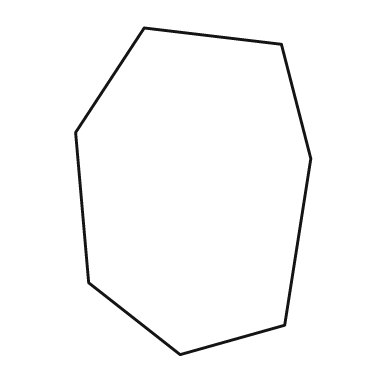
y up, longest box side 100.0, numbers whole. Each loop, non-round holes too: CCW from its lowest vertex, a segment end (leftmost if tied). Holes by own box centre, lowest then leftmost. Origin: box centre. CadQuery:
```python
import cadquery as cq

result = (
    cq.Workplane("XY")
    .moveTo(-4.0, -50.0)
    .lineTo(28.0, -41.0)
    .lineTo(36.0, 10.0)
    .lineTo(27.0, 45.0)
    .lineTo(-15.0, 50.0)
    .lineTo(-36.0, 18.0)
    .lineTo(-32.0, -28.0)
    .close()
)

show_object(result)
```